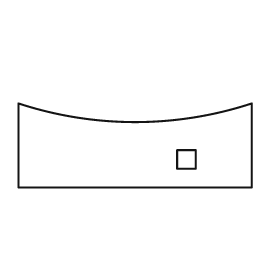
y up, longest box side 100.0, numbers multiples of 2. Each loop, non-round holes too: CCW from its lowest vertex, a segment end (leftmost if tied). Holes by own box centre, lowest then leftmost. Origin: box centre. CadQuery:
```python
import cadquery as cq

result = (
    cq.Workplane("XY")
    .moveTo(-50.0, -18.0)
    .lineTo(50.0, -18.0)
    .lineTo(50.0, 18.0)
    .threePointArc((0.0, 10.0), (-50.0, 18.0))
    .close()
    .moveTo(18.0, -10.0)
    .lineTo(26.0, -10.0)
    .lineTo(26.0, -2.0)
    .lineTo(18.0, -2.0)
    .close()
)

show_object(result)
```